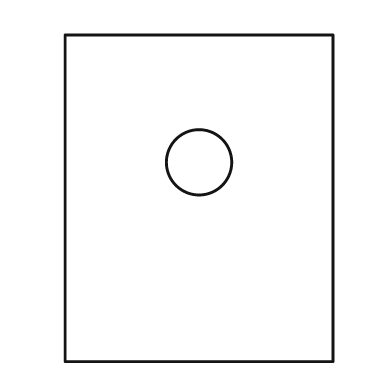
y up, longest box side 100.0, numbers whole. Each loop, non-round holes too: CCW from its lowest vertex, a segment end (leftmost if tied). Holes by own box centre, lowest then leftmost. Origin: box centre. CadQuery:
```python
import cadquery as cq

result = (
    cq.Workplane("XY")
    .moveTo(-41.0, -50.0)
    .lineTo(41.0, -50.0)
    .lineTo(41.0, 50.0)
    .lineTo(-41.0, 50.0)
    .close()
    .moveTo(0.0, 11.0)
    .circle(10.0)
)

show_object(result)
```